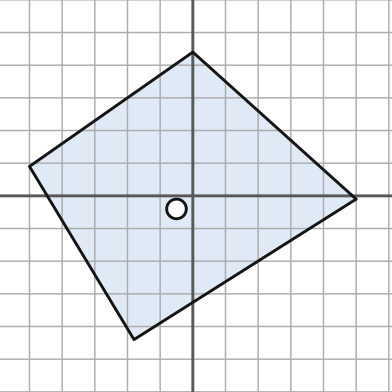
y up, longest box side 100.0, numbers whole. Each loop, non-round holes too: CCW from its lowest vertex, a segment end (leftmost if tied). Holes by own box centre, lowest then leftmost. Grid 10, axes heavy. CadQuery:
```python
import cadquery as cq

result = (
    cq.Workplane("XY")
    .moveTo(-18.0, -44.0)
    .lineTo(50.0, -1.0)
    .lineTo(0.0, 44.0)
    .lineTo(-50.0, 9.0)
    .close()
    .moveTo(-5.0, -4.0)
    .circle(3.0)
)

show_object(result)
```